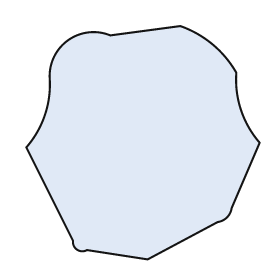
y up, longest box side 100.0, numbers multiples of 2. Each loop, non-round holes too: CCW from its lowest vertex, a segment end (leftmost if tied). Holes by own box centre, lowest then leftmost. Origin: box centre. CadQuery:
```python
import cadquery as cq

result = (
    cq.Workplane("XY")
    .moveTo(2.0, -50.0)
    .lineTo(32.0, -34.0)
    .threePointArc((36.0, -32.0), (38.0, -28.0))
    .lineTo(50.0, 0.0)
    .threePointArc((42.0, 14.0), (40.0, 30.0))
    .threePointArc((30.0, 42.0), (16.0, 50.0))
    .lineTo(-14.0, 46.0)
    .threePointArc((-32.0, 44.0), (-40.0, 28.0))
    .threePointArc((-42.0, 12.0), (-50.0, -2.0))
    .lineTo(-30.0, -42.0)
    .threePointArc((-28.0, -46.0), (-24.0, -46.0))
    .close()
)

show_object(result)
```